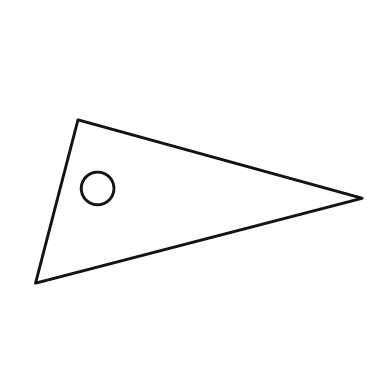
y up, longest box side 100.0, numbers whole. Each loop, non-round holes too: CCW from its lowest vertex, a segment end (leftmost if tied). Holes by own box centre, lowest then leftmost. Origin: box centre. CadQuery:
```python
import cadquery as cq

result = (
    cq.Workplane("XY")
    .moveTo(-50.0, -25.0)
    .lineTo(50.0, 1.0)
    .lineTo(-37.0, 25.0)
    .close()
    .moveTo(-31.0, 4.0)
    .circle(5.0)
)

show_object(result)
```